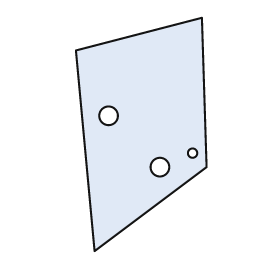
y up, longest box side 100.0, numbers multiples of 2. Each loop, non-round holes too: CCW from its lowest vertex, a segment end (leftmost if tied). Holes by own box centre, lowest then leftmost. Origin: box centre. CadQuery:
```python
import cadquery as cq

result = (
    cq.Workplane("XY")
    .moveTo(-20.0, -50.0)
    .lineTo(28.0, -14.0)
    .lineTo(26.0, 50.0)
    .lineTo(-28.0, 36.0)
    .close()
    .moveTo(8.0, -14.0)
    .circle(4.0)
    .moveTo(22.0, -8.0)
    .circle(2.0)
    .moveTo(-14.0, 8.0)
    .circle(4.0)
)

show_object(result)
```